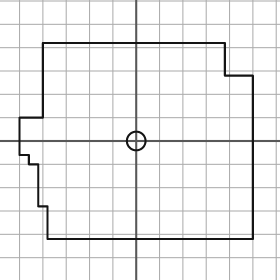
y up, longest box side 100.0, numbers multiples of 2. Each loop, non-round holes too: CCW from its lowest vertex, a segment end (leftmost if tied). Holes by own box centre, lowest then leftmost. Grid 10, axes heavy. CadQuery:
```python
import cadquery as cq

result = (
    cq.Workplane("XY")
    .moveTo(-38.0, -42.0)
    .lineTo(50.0, -42.0)
    .lineTo(50.0, 28.0)
    .lineTo(38.0, 28.0)
    .lineTo(38.0, 42.0)
    .lineTo(-40.0, 42.0)
    .lineTo(-40.0, 10.0)
    .lineTo(-50.0, 10.0)
    .lineTo(-50.0, -6.0)
    .lineTo(-46.0, -6.0)
    .lineTo(-46.0, -10.0)
    .lineTo(-42.0, -10.0)
    .lineTo(-42.0, -28.0)
    .lineTo(-38.0, -28.0)
    .close()
    .moveTo(0.0, 0.0)
    .circle(4.0)
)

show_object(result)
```